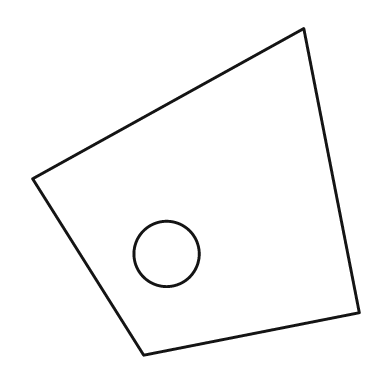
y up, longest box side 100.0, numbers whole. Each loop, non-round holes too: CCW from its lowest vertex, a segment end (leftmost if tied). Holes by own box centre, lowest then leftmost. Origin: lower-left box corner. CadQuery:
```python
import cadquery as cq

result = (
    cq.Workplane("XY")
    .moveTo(34.0, 0.0)
    .lineTo(100.0, 13.0)
    .lineTo(83.0, 100.0)
    .lineTo(0.0, 54.0)
    .close()
    .moveTo(41.0, 31.0)
    .circle(10.0)
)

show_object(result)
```